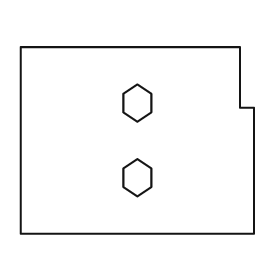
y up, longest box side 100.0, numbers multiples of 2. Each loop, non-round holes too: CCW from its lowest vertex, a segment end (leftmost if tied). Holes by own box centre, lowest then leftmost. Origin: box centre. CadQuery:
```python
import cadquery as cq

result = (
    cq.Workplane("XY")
    .moveTo(-50.0, -40.0)
    .lineTo(50.0, -40.0)
    .lineTo(50.0, 14.0)
    .lineTo(44.0, 14.0)
    .lineTo(44.0, 40.0)
    .lineTo(-50.0, 40.0)
    .close()
    .moveTo(0.0, -24.0)
    .lineTo(6.0, -20.0)
    .lineTo(6.0, -12.0)
    .lineTo(0.0, -8.0)
    .lineTo(-6.0, -12.0)
    .lineTo(-6.0, -20.0)
    .close()
    .moveTo(0.0, 8.0)
    .lineTo(6.0, 12.0)
    .lineTo(6.0, 20.0)
    .lineTo(0.0, 24.0)
    .lineTo(-6.0, 20.0)
    .lineTo(-6.0, 12.0)
    .close()
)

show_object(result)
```